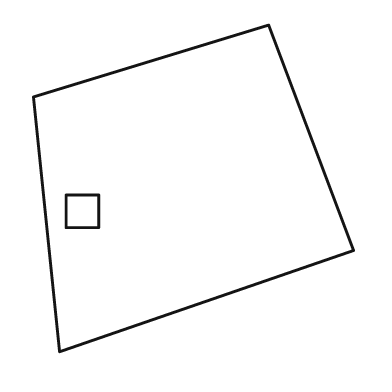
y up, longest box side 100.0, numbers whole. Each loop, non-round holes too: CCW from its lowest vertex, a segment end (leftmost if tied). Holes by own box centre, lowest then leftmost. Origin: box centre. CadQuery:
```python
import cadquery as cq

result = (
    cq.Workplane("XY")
    .moveTo(-41.0, -50.0)
    .lineTo(49.0, -19.0)
    .lineTo(23.0, 50.0)
    .lineTo(-49.0, 28.0)
    .close()
    .moveTo(-39.0, -12.0)
    .lineTo(-29.0, -12.0)
    .lineTo(-29.0, -2.0)
    .lineTo(-39.0, -2.0)
    .close()
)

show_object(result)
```